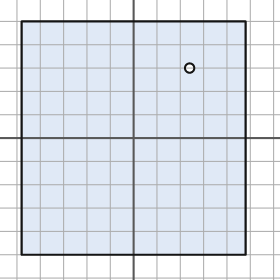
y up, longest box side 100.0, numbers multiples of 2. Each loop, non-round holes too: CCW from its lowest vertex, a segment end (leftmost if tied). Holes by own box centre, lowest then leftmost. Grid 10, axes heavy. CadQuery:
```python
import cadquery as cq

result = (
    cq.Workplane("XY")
    .moveTo(-48.0, -50.0)
    .lineTo(48.0, -50.0)
    .lineTo(48.0, 50.0)
    .lineTo(-48.0, 50.0)
    .close()
    .moveTo(24.0, 30.0)
    .circle(2.0)
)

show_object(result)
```